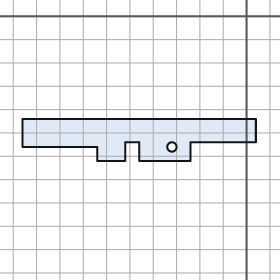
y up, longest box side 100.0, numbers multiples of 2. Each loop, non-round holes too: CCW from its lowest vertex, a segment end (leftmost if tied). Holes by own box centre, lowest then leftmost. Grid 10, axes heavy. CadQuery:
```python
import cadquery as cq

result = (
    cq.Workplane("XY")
    .moveTo(-64.0, -62.0)
    .lineTo(-52.0, -62.0)
    .lineTo(-52.0, -54.0)
    .lineTo(-46.0, -54.0)
    .lineTo(-46.0, -62.0)
    .lineTo(-24.0, -62.0)
    .lineTo(-24.0, -54.0)
    .lineTo(4.0, -54.0)
    .lineTo(4.0, -44.0)
    .lineTo(-96.0, -44.0)
    .lineTo(-96.0, -56.0)
    .lineTo(-64.0, -56.0)
    .close()
    .moveTo(-32.0, -56.0)
    .circle(2.0)
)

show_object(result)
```